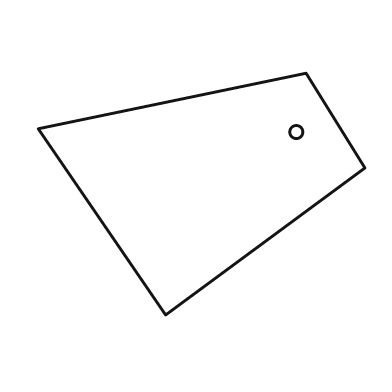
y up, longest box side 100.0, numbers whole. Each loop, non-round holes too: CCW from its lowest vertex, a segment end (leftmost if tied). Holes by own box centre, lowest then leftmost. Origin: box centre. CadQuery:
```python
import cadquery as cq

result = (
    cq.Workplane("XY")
    .moveTo(-11.0, -37.0)
    .lineTo(50.0, 8.0)
    .lineTo(32.0, 37.0)
    .lineTo(-50.0, 20.0)
    .close()
    .moveTo(29.0, 19.0)
    .circle(2.0)
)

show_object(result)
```